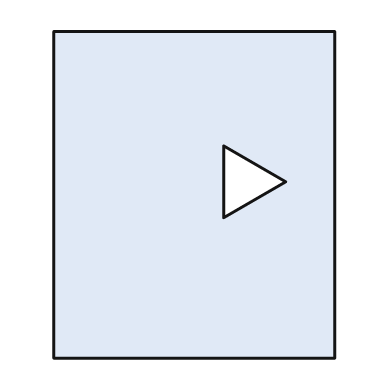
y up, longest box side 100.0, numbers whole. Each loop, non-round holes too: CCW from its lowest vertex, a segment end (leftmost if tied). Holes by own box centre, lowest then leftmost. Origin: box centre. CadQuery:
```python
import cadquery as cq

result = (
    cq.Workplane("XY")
    .moveTo(-43.0, -50.0)
    .lineTo(43.0, -50.0)
    .lineTo(43.0, 50.0)
    .lineTo(-43.0, 50.0)
    .close()
    .moveTo(9.0, -7.0)
    .lineTo(28.0, 4.0)
    .lineTo(9.0, 15.0)
    .close()
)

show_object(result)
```